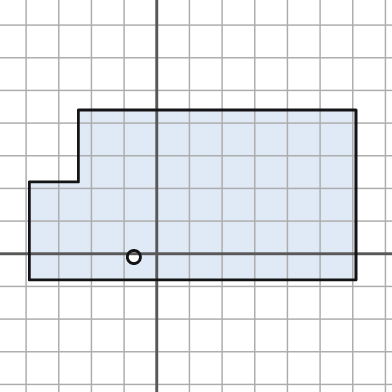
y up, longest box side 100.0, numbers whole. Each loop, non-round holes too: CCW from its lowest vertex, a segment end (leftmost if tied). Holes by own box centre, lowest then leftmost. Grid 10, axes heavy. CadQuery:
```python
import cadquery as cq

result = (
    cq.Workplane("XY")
    .moveTo(-39.0, -8.0)
    .lineTo(61.0, -8.0)
    .lineTo(61.0, 44.0)
    .lineTo(-24.0, 44.0)
    .lineTo(-24.0, 22.0)
    .lineTo(-39.0, 22.0)
    .close()
    .moveTo(-7.0, -1.0)
    .circle(2.0)
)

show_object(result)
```